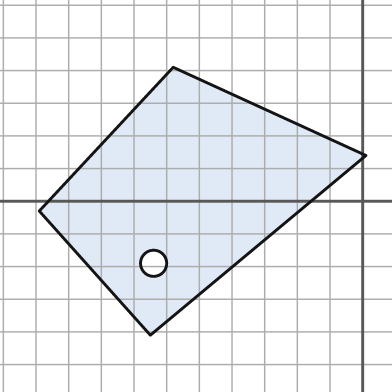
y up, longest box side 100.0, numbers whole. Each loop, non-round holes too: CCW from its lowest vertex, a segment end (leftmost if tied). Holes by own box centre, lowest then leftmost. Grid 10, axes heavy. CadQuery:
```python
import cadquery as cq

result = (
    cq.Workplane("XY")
    .moveTo(-65.0, -41.0)
    .lineTo(1.0, 14.0)
    .lineTo(-58.0, 41.0)
    .lineTo(-99.0, -3.0)
    .close()
    .moveTo(-64.0, -19.0)
    .circle(4.0)
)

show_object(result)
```